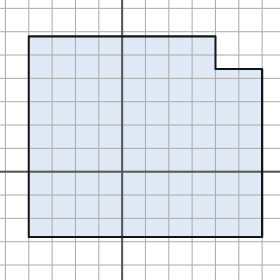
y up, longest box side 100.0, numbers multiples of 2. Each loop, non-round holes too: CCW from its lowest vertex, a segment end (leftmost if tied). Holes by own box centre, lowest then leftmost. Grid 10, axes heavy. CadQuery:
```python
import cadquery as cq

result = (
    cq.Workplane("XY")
    .moveTo(-40.0, -28.0)
    .lineTo(60.0, -28.0)
    .lineTo(60.0, 44.0)
    .lineTo(40.0, 44.0)
    .lineTo(40.0, 58.0)
    .lineTo(-40.0, 58.0)
    .close()
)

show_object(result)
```